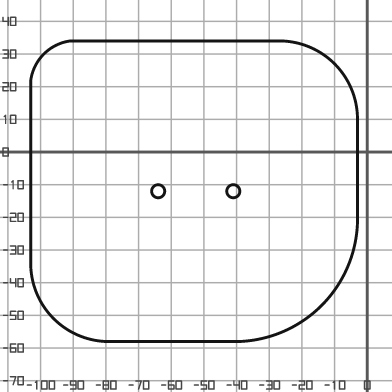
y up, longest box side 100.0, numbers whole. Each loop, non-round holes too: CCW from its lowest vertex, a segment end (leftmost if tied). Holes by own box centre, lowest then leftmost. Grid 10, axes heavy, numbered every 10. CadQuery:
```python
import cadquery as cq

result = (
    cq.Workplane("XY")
    .moveTo(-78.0, -58.0)
    .lineTo(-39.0, -58.0)
    .threePointArc((-14.0, -47.0), (-3.0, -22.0))
    .lineTo(-3.0, 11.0)
    .threePointArc((-10.0, 27.0), (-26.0, 34.0))
    .lineTo(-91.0, 34.0)
    .threePointArc((-99.0, 30.0), (-103.0, 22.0))
    .lineTo(-103.0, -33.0)
    .threePointArc((-96.0, -51.0), (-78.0, -58.0))
    .close()
    .moveTo(-64.0, -12.0)
    .circle(2.0)
    .moveTo(-41.0, -12.0)
    .circle(2.0)
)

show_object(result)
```